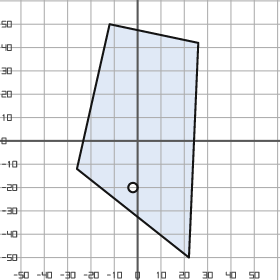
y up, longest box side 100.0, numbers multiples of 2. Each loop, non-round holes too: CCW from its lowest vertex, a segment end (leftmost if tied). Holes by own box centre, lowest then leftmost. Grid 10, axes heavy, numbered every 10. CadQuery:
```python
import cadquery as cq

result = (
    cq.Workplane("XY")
    .moveTo(22.0, -50.0)
    .lineTo(26.0, 42.0)
    .lineTo(-12.0, 50.0)
    .lineTo(-26.0, -12.0)
    .close()
    .moveTo(-2.0, -20.0)
    .circle(2.0)
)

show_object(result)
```